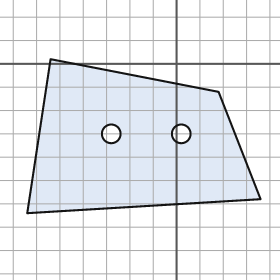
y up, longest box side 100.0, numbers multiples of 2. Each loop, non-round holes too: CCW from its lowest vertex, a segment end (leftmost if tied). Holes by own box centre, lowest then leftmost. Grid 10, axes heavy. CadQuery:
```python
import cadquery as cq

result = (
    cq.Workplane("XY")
    .moveTo(-64.0, -64.0)
    .lineTo(36.0, -58.0)
    .lineTo(18.0, -12.0)
    .lineTo(-54.0, 2.0)
    .close()
    .moveTo(-28.0, -30.0)
    .circle(4.0)
    .moveTo(2.0, -30.0)
    .circle(4.0)
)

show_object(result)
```